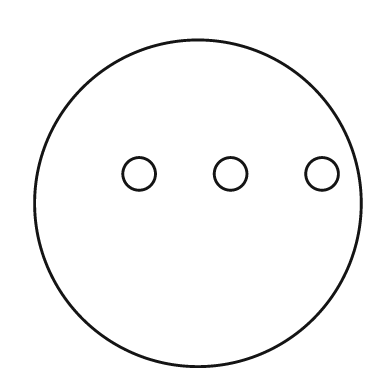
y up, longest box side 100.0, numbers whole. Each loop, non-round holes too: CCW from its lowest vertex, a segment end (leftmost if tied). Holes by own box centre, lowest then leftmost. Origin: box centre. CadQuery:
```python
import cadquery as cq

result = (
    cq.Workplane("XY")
    .moveTo(0.0, 0.0)
    .circle(50.0)
    .moveTo(-18.0, 9.0)
    .circle(5.0)
    .moveTo(10.0, 9.0)
    .circle(5.0)
    .moveTo(38.0, 9.0)
    .circle(5.0)
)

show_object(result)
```